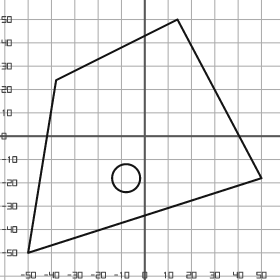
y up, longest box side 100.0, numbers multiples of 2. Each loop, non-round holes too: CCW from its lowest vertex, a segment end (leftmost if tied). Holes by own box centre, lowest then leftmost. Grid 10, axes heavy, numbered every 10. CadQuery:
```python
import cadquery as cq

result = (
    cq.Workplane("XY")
    .moveTo(-50.0, -50.0)
    .lineTo(50.0, -18.0)
    .lineTo(14.0, 50.0)
    .lineTo(-38.0, 24.0)
    .close()
    .moveTo(-8.0, -18.0)
    .circle(6.0)
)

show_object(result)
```